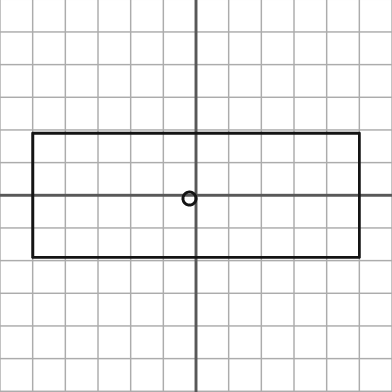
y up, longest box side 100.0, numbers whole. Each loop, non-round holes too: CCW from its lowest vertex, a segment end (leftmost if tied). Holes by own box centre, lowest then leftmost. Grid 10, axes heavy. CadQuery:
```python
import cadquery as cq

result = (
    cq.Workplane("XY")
    .moveTo(-50.0, -19.0)
    .lineTo(50.0, -19.0)
    .lineTo(50.0, 19.0)
    .lineTo(-50.0, 19.0)
    .close()
    .moveTo(-2.0, -1.0)
    .circle(2.0)
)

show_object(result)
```